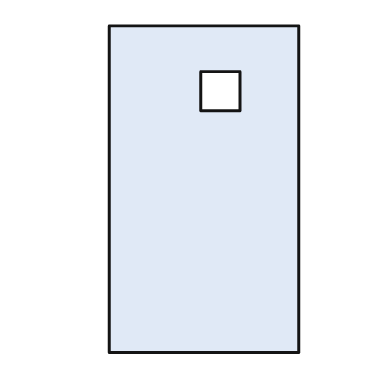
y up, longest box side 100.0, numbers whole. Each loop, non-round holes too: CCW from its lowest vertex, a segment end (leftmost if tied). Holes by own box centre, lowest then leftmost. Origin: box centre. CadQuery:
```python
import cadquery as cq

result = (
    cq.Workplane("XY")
    .moveTo(-29.0, -50.0)
    .lineTo(29.0, -50.0)
    .lineTo(29.0, 50.0)
    .lineTo(-29.0, 50.0)
    .close()
    .moveTo(-1.0, 24.0)
    .lineTo(11.0, 24.0)
    .lineTo(11.0, 36.0)
    .lineTo(-1.0, 36.0)
    .close()
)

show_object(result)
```